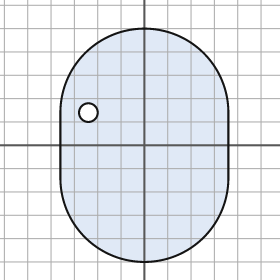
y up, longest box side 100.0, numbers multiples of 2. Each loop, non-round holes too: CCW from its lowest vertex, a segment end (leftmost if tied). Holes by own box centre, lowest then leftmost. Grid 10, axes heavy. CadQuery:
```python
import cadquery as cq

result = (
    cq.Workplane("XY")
    .moveTo(-36.0, -14.0)
    .threePointArc((0.0, -50.0), (36.0, -14.0))
    .lineTo(36.0, 14.0)
    .threePointArc((0.0, 50.0), (-36.0, 14.0))
    .close()
    .moveTo(-24.0, 14.0)
    .circle(4.0)
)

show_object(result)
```